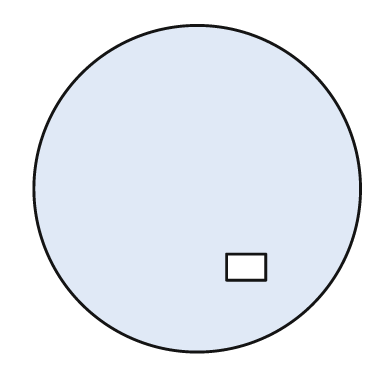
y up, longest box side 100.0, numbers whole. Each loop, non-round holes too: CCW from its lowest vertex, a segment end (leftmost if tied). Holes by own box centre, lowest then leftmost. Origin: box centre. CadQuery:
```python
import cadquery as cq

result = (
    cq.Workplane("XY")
    .moveTo(0.0, 0.0)
    .circle(50.0)
    .moveTo(9.0, -28.0)
    .lineTo(21.0, -28.0)
    .lineTo(21.0, -20.0)
    .lineTo(9.0, -20.0)
    .close()
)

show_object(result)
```